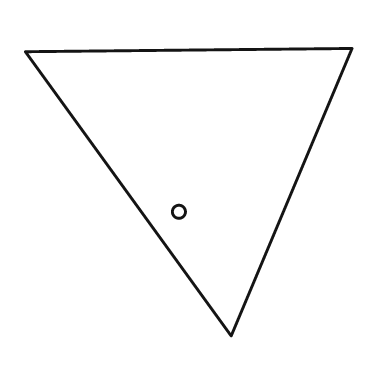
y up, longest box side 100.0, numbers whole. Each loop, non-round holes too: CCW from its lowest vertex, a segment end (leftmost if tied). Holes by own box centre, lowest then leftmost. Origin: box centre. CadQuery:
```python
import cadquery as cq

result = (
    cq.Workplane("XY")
    .moveTo(13.0, -44.0)
    .lineTo(50.0, 44.0)
    .lineTo(-50.0, 43.0)
    .close()
    .moveTo(-3.0, -6.0)
    .circle(2.0)
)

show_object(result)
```